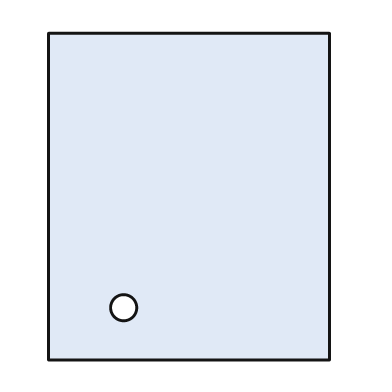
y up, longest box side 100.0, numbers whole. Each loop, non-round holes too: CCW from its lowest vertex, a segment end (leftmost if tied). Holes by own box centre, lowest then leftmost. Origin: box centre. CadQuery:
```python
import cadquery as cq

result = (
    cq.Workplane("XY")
    .moveTo(-43.0, -50.0)
    .lineTo(43.0, -50.0)
    .lineTo(43.0, 50.0)
    .lineTo(-43.0, 50.0)
    .close()
    .moveTo(-20.0, -34.0)
    .circle(4.0)
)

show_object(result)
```